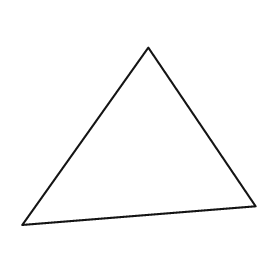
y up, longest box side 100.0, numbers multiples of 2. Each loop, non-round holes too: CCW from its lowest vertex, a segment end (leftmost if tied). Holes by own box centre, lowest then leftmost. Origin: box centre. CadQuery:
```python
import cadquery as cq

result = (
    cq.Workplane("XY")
    .moveTo(-50.0, -38.0)
    .lineTo(50.0, -30.0)
    .lineTo(4.0, 38.0)
    .close()
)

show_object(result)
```